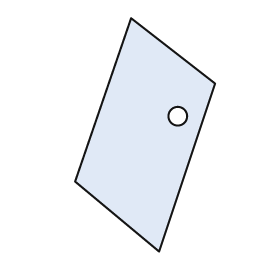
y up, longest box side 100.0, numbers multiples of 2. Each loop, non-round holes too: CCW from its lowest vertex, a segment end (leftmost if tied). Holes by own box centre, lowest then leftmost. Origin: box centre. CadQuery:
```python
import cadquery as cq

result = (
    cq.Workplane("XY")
    .moveTo(6.0, -50.0)
    .lineTo(30.0, 22.0)
    .lineTo(-6.0, 50.0)
    .lineTo(-30.0, -20.0)
    .close()
    .moveTo(14.0, 8.0)
    .circle(4.0)
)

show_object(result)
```